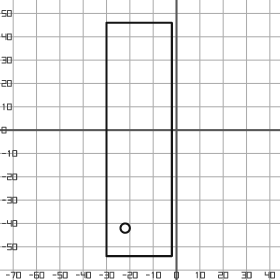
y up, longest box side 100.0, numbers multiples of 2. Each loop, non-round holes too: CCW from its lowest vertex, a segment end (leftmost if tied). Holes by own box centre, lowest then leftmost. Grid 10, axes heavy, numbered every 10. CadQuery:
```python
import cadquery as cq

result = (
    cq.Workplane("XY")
    .moveTo(-30.0, -54.0)
    .lineTo(-2.0, -54.0)
    .lineTo(-2.0, 46.0)
    .lineTo(-30.0, 46.0)
    .close()
    .moveTo(-22.0, -42.0)
    .circle(2.0)
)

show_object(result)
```